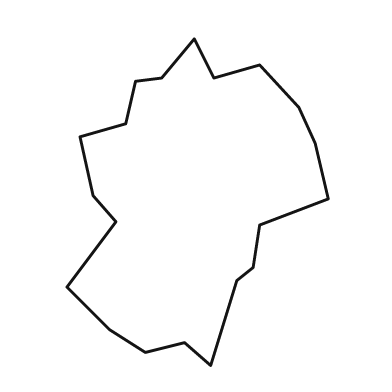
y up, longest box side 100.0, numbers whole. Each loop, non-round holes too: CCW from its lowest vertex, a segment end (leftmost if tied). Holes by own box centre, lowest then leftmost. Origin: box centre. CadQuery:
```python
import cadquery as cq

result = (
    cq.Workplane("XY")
    .moveTo(4.0, -50.0)
    .lineTo(12.0, -24.0)
    .lineTo(17.0, -20.0)
    .lineTo(19.0, -7.0)
    .lineTo(40.0, 1.0)
    .lineTo(36.0, 18.0)
    .lineTo(31.0, 29.0)
    .lineTo(19.0, 42.0)
    .lineTo(5.0, 38.0)
    .lineTo(-1.0, 50.0)
    .lineTo(-11.0, 38.0)
    .lineTo(-19.0, 37.0)
    .lineTo(-22.0, 24.0)
    .lineTo(-36.0, 20.0)
    .lineTo(-32.0, 2.0)
    .lineTo(-25.0, -6.0)
    .lineTo(-40.0, -26.0)
    .lineTo(-27.0, -39.0)
    .lineTo(-16.0, -46.0)
    .lineTo(-4.0, -43.0)
    .close()
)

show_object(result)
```